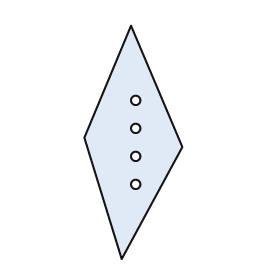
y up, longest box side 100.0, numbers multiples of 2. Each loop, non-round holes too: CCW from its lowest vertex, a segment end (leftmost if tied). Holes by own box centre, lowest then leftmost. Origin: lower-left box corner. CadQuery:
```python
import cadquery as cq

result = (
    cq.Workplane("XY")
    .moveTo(16.0, 0.0)
    .lineTo(42.0, 48.0)
    .lineTo(20.0, 100.0)
    .lineTo(0.0, 52.0)
    .close()
    .moveTo(22.0, 32.0)
    .circle(2.0)
    .moveTo(22.0, 44.0)
    .circle(2.0)
    .moveTo(22.0, 56.0)
    .circle(2.0)
    .moveTo(22.0, 68.0)
    .circle(2.0)
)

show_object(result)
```